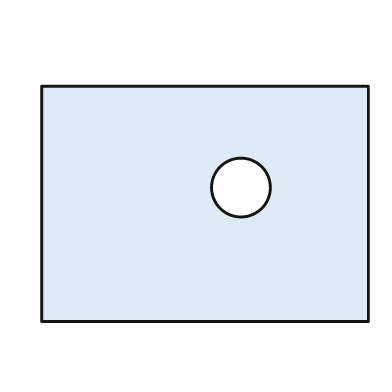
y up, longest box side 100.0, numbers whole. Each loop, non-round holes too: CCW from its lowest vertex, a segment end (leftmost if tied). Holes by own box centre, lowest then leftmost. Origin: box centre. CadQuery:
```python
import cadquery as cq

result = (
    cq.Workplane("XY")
    .moveTo(-50.0, -36.0)
    .lineTo(50.0, -36.0)
    .lineTo(50.0, 36.0)
    .lineTo(-50.0, 36.0)
    .close()
    .moveTo(11.0, 5.0)
    .circle(9.0)
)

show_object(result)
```